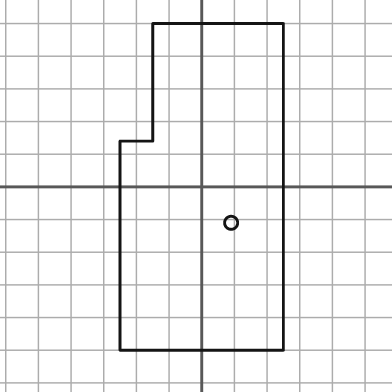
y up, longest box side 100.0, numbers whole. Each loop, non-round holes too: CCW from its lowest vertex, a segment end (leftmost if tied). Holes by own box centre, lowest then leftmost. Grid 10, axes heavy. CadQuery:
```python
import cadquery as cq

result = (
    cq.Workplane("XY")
    .moveTo(-25.0, -50.0)
    .lineTo(25.0, -50.0)
    .lineTo(25.0, 50.0)
    .lineTo(-15.0, 50.0)
    .lineTo(-15.0, 14.0)
    .lineTo(-25.0, 14.0)
    .close()
    .moveTo(9.0, -11.0)
    .circle(2.0)
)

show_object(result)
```